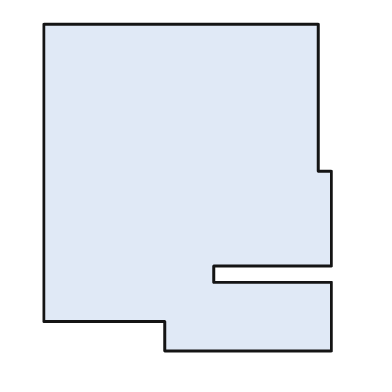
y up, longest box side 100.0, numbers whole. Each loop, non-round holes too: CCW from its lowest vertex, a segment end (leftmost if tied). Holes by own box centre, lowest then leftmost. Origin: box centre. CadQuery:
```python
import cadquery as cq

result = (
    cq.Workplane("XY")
    .moveTo(-7.0, -50.0)
    .lineTo(44.0, -50.0)
    .lineTo(44.0, -29.0)
    .lineTo(8.0, -29.0)
    .lineTo(8.0, -24.0)
    .lineTo(44.0, -24.0)
    .lineTo(44.0, 5.0)
    .lineTo(40.0, 5.0)
    .lineTo(40.0, 50.0)
    .lineTo(-44.0, 50.0)
    .lineTo(-44.0, -41.0)
    .lineTo(-7.0, -41.0)
    .close()
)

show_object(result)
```